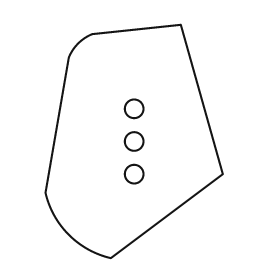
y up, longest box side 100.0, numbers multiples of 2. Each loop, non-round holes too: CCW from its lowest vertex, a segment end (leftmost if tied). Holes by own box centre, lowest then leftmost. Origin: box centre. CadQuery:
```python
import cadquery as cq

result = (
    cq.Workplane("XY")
    .moveTo(-10.0, -50.0)
    .lineTo(38.0, -14.0)
    .lineTo(20.0, 50.0)
    .lineTo(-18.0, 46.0)
    .threePointArc((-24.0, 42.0), (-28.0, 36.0))
    .lineTo(-38.0, -22.0)
    .threePointArc((-28.0, -40.0), (-10.0, -50.0))
    .close()
    .moveTo(0.0, -14.0)
    .circle(4.0)
    .moveTo(0.0, 0.0)
    .circle(4.0)
    .moveTo(0.0, 14.0)
    .circle(4.0)
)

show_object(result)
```